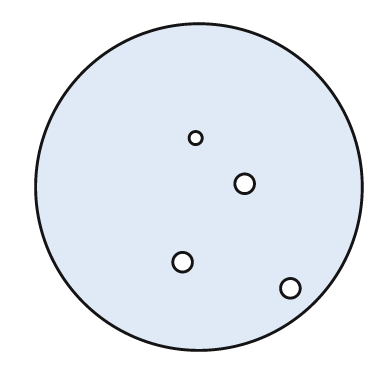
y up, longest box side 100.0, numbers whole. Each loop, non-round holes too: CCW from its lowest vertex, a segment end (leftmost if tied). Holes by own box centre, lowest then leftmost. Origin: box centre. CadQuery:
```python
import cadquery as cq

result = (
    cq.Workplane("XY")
    .moveTo(0.0, 0.0)
    .circle(50.0)
    .moveTo(28.0, -31.0)
    .circle(3.0)
    .moveTo(-5.0, -23.0)
    .circle(3.0)
    .moveTo(14.0, 1.0)
    .circle(3.0)
    .moveTo(-1.0, 15.0)
    .circle(2.0)
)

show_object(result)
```